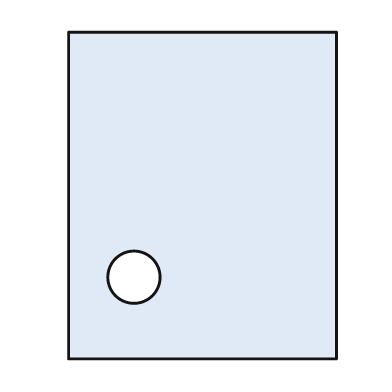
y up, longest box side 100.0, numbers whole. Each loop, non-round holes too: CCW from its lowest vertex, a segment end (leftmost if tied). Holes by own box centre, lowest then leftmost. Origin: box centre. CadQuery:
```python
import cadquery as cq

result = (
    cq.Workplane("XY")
    .moveTo(-41.0, -50.0)
    .lineTo(41.0, -50.0)
    .lineTo(41.0, 50.0)
    .lineTo(-41.0, 50.0)
    .close()
    .moveTo(-21.0, -25.0)
    .circle(8.0)
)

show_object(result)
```